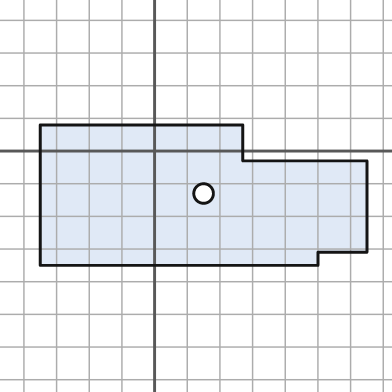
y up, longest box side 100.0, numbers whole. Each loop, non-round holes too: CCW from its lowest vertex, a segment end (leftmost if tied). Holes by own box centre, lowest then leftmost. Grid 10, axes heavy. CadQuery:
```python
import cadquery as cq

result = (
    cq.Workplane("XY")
    .moveTo(-35.0, -35.0)
    .lineTo(50.0, -35.0)
    .lineTo(50.0, -31.0)
    .lineTo(65.0, -31.0)
    .lineTo(65.0, -3.0)
    .lineTo(27.0, -3.0)
    .lineTo(27.0, 8.0)
    .lineTo(-35.0, 8.0)
    .close()
    .moveTo(15.0, -13.0)
    .circle(3.0)
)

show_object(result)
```